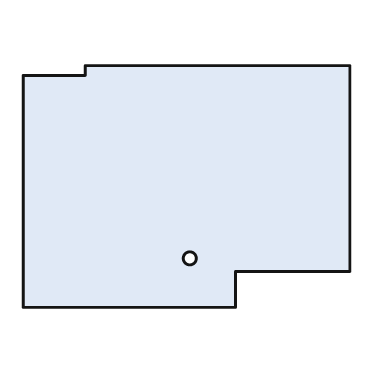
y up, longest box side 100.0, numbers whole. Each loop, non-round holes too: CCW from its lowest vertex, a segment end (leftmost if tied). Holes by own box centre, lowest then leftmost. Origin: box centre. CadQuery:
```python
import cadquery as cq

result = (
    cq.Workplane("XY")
    .moveTo(-50.0, -37.0)
    .lineTo(15.0, -37.0)
    .lineTo(15.0, -26.0)
    .lineTo(50.0, -26.0)
    .lineTo(50.0, 37.0)
    .lineTo(-31.0, 37.0)
    .lineTo(-31.0, 34.0)
    .lineTo(-50.0, 34.0)
    .close()
    .moveTo(1.0, -22.0)
    .circle(2.0)
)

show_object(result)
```